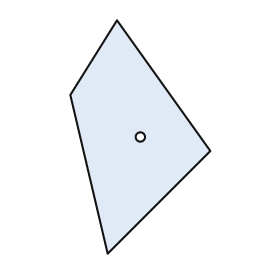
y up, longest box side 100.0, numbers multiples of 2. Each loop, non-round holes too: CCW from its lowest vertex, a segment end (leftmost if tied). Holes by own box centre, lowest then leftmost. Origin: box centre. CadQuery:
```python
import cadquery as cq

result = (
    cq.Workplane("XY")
    .moveTo(-14.0, -50.0)
    .lineTo(30.0, -6.0)
    .lineTo(-10.0, 50.0)
    .lineTo(-30.0, 18.0)
    .close()
    .moveTo(0.0, 0.0)
    .circle(2.0)
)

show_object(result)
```